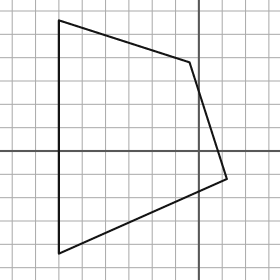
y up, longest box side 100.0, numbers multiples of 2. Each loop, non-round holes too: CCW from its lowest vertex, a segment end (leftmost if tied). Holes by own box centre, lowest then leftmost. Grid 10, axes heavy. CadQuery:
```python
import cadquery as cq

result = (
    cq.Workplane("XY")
    .moveTo(-60.0, -44.0)
    .lineTo(12.0, -12.0)
    .lineTo(-4.0, 38.0)
    .lineTo(-60.0, 56.0)
    .close()
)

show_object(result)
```